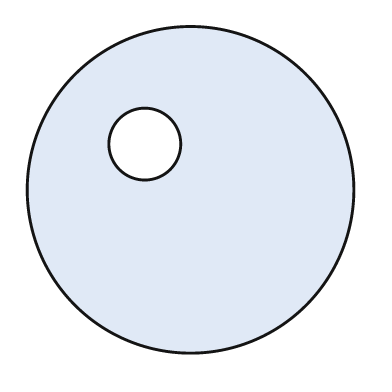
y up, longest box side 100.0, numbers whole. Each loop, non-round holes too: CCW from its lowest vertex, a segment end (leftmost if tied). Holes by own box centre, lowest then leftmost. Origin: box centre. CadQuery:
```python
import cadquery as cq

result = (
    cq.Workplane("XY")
    .moveTo(0.0, 0.0)
    .circle(50.0)
    .moveTo(-14.0, 14.0)
    .circle(11.0)
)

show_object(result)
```